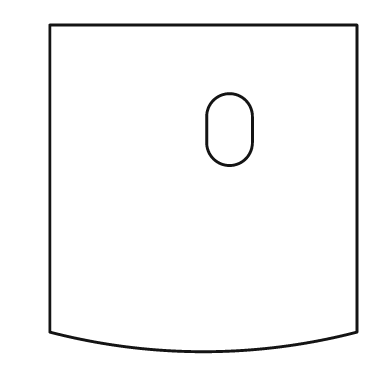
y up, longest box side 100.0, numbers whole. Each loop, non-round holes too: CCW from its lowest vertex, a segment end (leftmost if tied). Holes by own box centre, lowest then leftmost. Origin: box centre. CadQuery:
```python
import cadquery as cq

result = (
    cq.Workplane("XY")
    .moveTo(-47.0, -44.0)
    .threePointArc((0.0, -50.0), (47.0, -44.0))
    .lineTo(47.0, 50.0)
    .lineTo(-47.0, 50.0)
    .close()
    .moveTo(1.0, 14.0)
    .threePointArc((8.0, 7.0), (15.0, 14.0))
    .lineTo(15.0, 22.0)
    .threePointArc((8.0, 29.0), (1.0, 22.0))
    .close()
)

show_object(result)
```